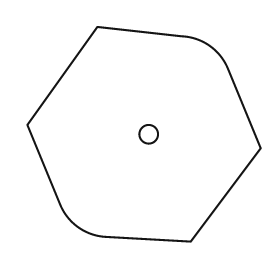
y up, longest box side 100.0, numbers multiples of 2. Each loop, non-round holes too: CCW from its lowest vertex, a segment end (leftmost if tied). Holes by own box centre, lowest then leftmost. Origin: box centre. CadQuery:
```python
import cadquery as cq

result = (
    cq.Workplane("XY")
    .moveTo(20.0, -46.0)
    .lineTo(50.0, -6.0)
    .lineTo(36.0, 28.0)
    .threePointArc((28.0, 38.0), (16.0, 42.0))
    .lineTo(-20.0, 46.0)
    .lineTo(-50.0, 4.0)
    .lineTo(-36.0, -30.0)
    .threePointArc((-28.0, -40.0), (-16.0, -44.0))
    .close()
    .moveTo(2.0, 0.0)
    .circle(4.0)
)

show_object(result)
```